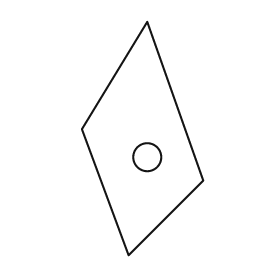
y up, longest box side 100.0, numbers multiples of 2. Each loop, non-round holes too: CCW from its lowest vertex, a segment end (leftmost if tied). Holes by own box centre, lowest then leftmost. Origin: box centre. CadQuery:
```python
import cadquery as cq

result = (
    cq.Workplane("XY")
    .moveTo(-6.0, -50.0)
    .lineTo(26.0, -18.0)
    .lineTo(2.0, 50.0)
    .lineTo(-26.0, 4.0)
    .close()
    .moveTo(2.0, -8.0)
    .circle(6.0)
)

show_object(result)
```